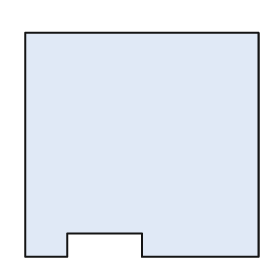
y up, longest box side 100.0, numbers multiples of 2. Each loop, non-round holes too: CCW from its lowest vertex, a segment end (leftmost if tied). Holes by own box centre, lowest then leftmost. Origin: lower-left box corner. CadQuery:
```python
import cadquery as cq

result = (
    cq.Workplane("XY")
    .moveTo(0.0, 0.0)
    .lineTo(18.0, 0.0)
    .lineTo(18.0, 10.0)
    .lineTo(50.0, 10.0)
    .lineTo(50.0, 0.0)
    .lineTo(100.0, 0.0)
    .lineTo(100.0, 96.0)
    .lineTo(0.0, 96.0)
    .close()
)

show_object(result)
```